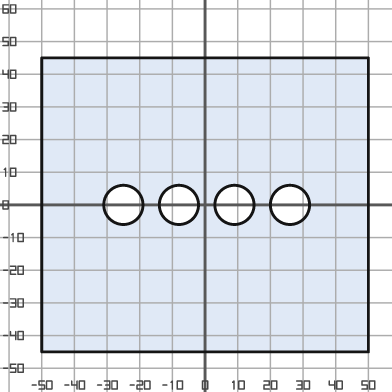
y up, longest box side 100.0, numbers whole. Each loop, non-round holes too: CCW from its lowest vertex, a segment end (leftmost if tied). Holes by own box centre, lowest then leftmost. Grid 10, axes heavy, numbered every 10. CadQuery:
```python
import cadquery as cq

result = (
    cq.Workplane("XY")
    .moveTo(-50.0, -45.0)
    .lineTo(50.0, -45.0)
    .lineTo(50.0, 45.0)
    .lineTo(-50.0, 45.0)
    .close()
    .moveTo(-25.0, 0.0)
    .circle(6.0)
    .moveTo(-8.0, 0.0)
    .circle(6.0)
    .moveTo(9.0, 0.0)
    .circle(6.0)
    .moveTo(26.0, 0.0)
    .circle(6.0)
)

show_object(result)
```